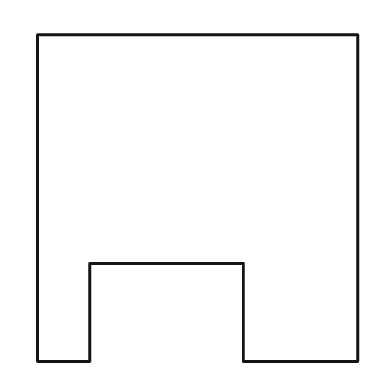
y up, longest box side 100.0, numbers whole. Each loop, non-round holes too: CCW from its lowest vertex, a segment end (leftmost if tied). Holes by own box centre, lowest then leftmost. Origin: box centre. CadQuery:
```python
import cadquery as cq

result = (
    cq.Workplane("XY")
    .moveTo(-49.0, -50.0)
    .lineTo(-33.0, -50.0)
    .lineTo(-33.0, -20.0)
    .lineTo(14.0, -20.0)
    .lineTo(14.0, -50.0)
    .lineTo(49.0, -50.0)
    .lineTo(49.0, 50.0)
    .lineTo(-49.0, 50.0)
    .close()
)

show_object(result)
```